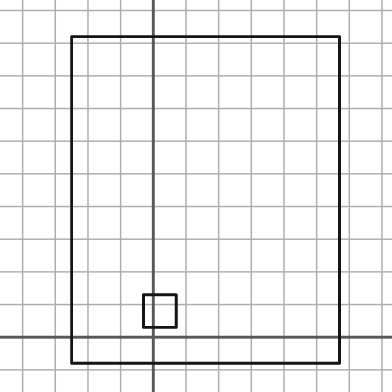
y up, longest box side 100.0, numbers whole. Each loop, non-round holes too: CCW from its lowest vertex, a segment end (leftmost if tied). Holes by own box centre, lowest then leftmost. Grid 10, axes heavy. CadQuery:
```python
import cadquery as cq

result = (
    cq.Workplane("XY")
    .moveTo(-25.0, -8.0)
    .lineTo(57.0, -8.0)
    .lineTo(57.0, 92.0)
    .lineTo(-25.0, 92.0)
    .close()
    .moveTo(-3.0, 3.0)
    .lineTo(7.0, 3.0)
    .lineTo(7.0, 13.0)
    .lineTo(-3.0, 13.0)
    .close()
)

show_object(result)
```